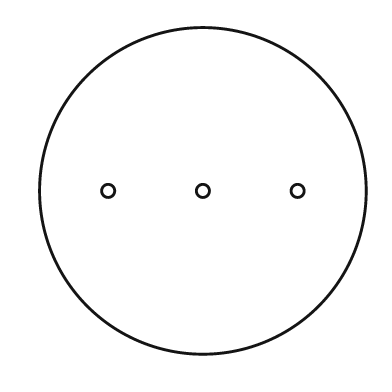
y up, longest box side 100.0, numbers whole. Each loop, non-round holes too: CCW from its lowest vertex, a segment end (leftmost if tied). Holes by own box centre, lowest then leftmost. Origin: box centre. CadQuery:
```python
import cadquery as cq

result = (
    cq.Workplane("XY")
    .moveTo(0.0, 0.0)
    .circle(50.0)
    .moveTo(-29.0, 0.0)
    .circle(2.0)
    .moveTo(0.0, 0.0)
    .circle(2.0)
    .moveTo(29.0, 0.0)
    .circle(2.0)
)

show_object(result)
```